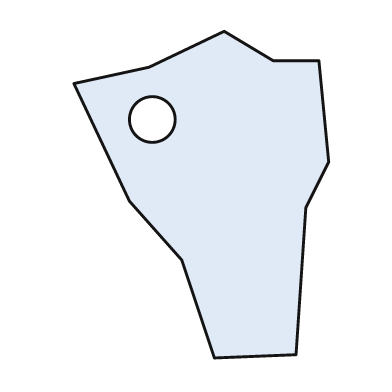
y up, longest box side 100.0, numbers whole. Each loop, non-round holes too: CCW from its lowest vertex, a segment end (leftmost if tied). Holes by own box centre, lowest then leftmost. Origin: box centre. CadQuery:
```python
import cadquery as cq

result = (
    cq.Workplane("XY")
    .moveTo(4.0, -50.0)
    .lineTo(29.0, -49.0)
    .lineTo(32.0, -4.0)
    .lineTo(39.0, 10.0)
    .lineTo(36.0, 41.0)
    .lineTo(22.0, 41.0)
    .lineTo(7.0, 50.0)
    .lineTo(-16.0, 39.0)
    .lineTo(-39.0, 34.0)
    .lineTo(-22.0, -2.0)
    .lineTo(-6.0, -20.0)
    .close()
    .moveTo(-15.0, 23.0)
    .circle(7.0)
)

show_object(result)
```